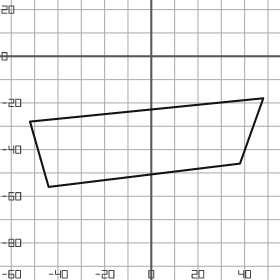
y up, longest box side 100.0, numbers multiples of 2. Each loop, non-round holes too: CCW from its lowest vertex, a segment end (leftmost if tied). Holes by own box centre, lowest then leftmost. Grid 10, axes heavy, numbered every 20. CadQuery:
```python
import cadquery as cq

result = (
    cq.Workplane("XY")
    .moveTo(-44.0, -56.0)
    .lineTo(38.0, -46.0)
    .lineTo(48.0, -18.0)
    .lineTo(-52.0, -28.0)
    .close()
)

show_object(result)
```